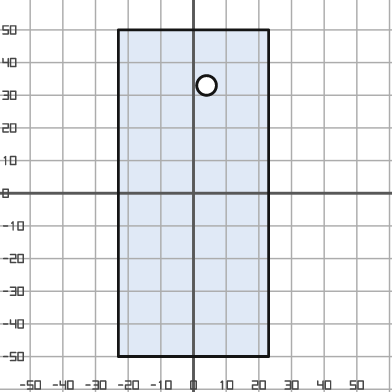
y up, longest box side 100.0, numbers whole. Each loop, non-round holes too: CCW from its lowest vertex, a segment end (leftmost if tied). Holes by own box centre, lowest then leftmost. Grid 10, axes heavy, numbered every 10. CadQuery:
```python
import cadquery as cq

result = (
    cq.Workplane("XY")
    .moveTo(-23.0, -50.0)
    .lineTo(23.0, -50.0)
    .lineTo(23.0, 50.0)
    .lineTo(-23.0, 50.0)
    .close()
    .moveTo(4.0, 33.0)
    .circle(3.0)
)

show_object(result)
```